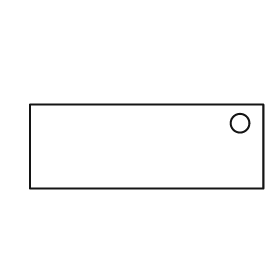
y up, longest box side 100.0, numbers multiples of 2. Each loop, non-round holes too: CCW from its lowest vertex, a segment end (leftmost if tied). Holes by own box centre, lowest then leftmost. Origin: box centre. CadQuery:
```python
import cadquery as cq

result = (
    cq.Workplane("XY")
    .moveTo(-50.0, -18.0)
    .lineTo(50.0, -18.0)
    .lineTo(50.0, 18.0)
    .lineTo(-50.0, 18.0)
    .close()
    .moveTo(40.0, 10.0)
    .circle(4.0)
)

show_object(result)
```